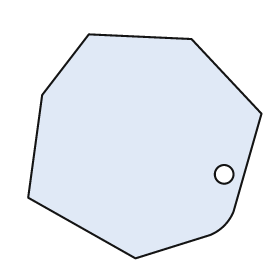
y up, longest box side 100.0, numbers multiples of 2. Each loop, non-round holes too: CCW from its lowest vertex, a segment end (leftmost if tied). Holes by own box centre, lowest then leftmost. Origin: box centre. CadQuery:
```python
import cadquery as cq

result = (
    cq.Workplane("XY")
    .moveTo(-4.0, -48.0)
    .lineTo(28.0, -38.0)
    .threePointArc((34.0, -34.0), (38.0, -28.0))
    .lineTo(50.0, 14.0)
    .lineTo(20.0, 46.0)
    .lineTo(-24.0, 48.0)
    .lineTo(-44.0, 22.0)
    .lineTo(-50.0, -22.0)
    .close()
    .moveTo(34.0, -12.0)
    .circle(4.0)
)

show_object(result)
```